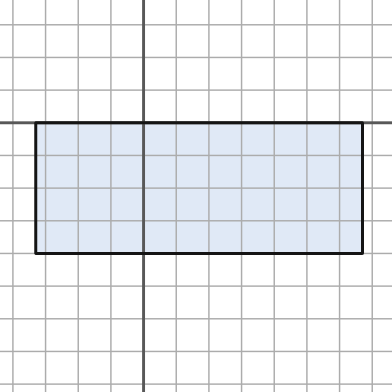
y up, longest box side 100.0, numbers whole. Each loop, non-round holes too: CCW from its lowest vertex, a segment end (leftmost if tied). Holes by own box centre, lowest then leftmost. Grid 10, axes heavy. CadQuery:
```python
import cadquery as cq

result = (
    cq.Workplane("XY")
    .moveTo(-33.0, -40.0)
    .lineTo(67.0, -40.0)
    .lineTo(67.0, 0.0)
    .lineTo(-33.0, 0.0)
    .close()
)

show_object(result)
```